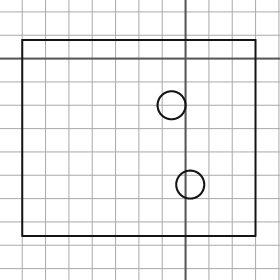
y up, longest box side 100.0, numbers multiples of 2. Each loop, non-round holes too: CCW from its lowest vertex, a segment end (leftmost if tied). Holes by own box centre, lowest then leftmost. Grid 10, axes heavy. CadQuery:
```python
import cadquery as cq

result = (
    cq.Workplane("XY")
    .moveTo(-70.0, -76.0)
    .lineTo(30.0, -76.0)
    .lineTo(30.0, 8.0)
    .lineTo(-70.0, 8.0)
    .close()
    .moveTo(2.0, -54.0)
    .circle(6.0)
    .moveTo(-6.0, -20.0)
    .circle(6.0)
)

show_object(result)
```